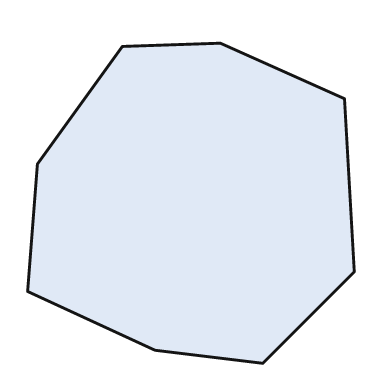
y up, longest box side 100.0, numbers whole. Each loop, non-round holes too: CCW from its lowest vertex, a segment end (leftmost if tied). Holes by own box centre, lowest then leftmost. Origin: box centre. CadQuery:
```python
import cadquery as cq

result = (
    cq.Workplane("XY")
    .moveTo(22.0, -49.0)
    .lineTo(50.0, -21.0)
    .lineTo(47.0, 32.0)
    .lineTo(9.0, 49.0)
    .lineTo(-21.0, 48.0)
    .lineTo(-47.0, 12.0)
    .lineTo(-50.0, -27.0)
    .lineTo(-11.0, -45.0)
    .close()
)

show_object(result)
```